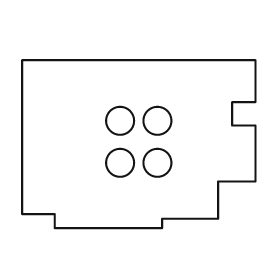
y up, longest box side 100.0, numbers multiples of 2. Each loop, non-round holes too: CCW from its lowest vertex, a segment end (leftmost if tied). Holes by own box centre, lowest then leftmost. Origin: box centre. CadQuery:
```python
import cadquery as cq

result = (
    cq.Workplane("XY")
    .moveTo(-36.0, -36.0)
    .lineTo(10.0, -36.0)
    .lineTo(10.0, -32.0)
    .lineTo(34.0, -32.0)
    .lineTo(34.0, -16.0)
    .lineTo(50.0, -16.0)
    .lineTo(50.0, 8.0)
    .lineTo(40.0, 8.0)
    .lineTo(40.0, 18.0)
    .lineTo(50.0, 18.0)
    .lineTo(50.0, 36.0)
    .lineTo(-50.0, 36.0)
    .lineTo(-50.0, -30.0)
    .lineTo(-36.0, -30.0)
    .close()
    .moveTo(-8.0, -8.0)
    .circle(6.0)
    .moveTo(8.0, -8.0)
    .circle(6.0)
    .moveTo(-8.0, 10.0)
    .circle(6.0)
    .moveTo(8.0, 10.0)
    .circle(6.0)
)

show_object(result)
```